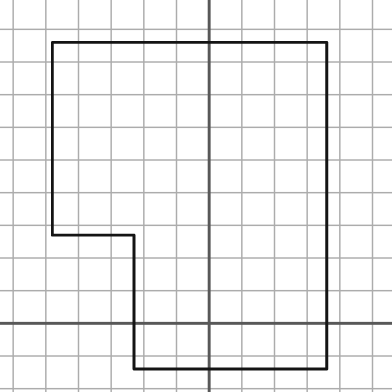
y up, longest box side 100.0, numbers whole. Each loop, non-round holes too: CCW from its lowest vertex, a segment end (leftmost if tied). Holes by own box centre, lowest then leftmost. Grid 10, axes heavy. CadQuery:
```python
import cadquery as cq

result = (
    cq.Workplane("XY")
    .moveTo(-23.0, -14.0)
    .lineTo(36.0, -14.0)
    .lineTo(36.0, 86.0)
    .lineTo(-48.0, 86.0)
    .lineTo(-48.0, 27.0)
    .lineTo(-23.0, 27.0)
    .close()
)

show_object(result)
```